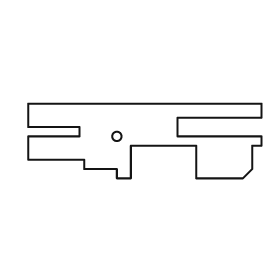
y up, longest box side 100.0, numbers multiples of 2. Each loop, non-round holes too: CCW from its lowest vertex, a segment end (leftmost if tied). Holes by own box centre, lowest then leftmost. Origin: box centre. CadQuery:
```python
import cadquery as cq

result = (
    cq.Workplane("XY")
    .moveTo(-12.0, -16.0)
    .lineTo(-6.0, -16.0)
    .lineTo(-6.0, -2.0)
    .lineTo(22.0, -2.0)
    .lineTo(22.0, -16.0)
    .lineTo(42.0, -16.0)
    .lineTo(46.0, -12.0)
    .lineTo(46.0, -2.0)
    .lineTo(50.0, -2.0)
    .lineTo(50.0, 2.0)
    .lineTo(14.0, 2.0)
    .lineTo(14.0, 10.0)
    .lineTo(50.0, 10.0)
    .lineTo(50.0, 16.0)
    .lineTo(-50.0, 16.0)
    .lineTo(-50.0, 6.0)
    .lineTo(-28.0, 6.0)
    .lineTo(-28.0, 2.0)
    .lineTo(-50.0, 2.0)
    .lineTo(-50.0, -8.0)
    .lineTo(-26.0, -8.0)
    .lineTo(-26.0, -12.0)
    .lineTo(-12.0, -12.0)
    .close()
    .moveTo(-12.0, 2.0)
    .circle(2.0)
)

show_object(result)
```